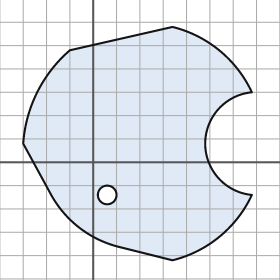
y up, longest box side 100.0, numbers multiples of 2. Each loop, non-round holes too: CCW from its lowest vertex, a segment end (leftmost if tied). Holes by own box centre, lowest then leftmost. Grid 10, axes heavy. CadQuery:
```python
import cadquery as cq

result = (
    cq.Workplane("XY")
    .moveTo(34.0, -42.0)
    .threePointArc((54.0, -32.0), (68.0, -14.0))
    .threePointArc((48.0, 8.0), (68.0, 30.0))
    .threePointArc((54.0, 48.0), (34.0, 58.0))
    .lineTo(-10.0, 48.0)
    .threePointArc((-24.0, 30.0), (-30.0, 8.0))
    .lineTo(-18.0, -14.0)
    .threePointArc((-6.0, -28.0), (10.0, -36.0))
    .close()
    .moveTo(6.0, -14.0)
    .circle(4.0)
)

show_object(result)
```